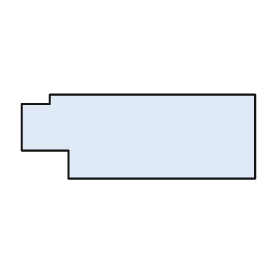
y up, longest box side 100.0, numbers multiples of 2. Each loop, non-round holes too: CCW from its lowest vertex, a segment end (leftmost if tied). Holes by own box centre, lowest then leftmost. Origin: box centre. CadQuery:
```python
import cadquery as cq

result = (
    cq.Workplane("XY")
    .moveTo(-30.0, -18.0)
    .lineTo(50.0, -18.0)
    .lineTo(50.0, 18.0)
    .lineTo(-38.0, 18.0)
    .lineTo(-38.0, 14.0)
    .lineTo(-50.0, 14.0)
    .lineTo(-50.0, -6.0)
    .lineTo(-30.0, -6.0)
    .close()
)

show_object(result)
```